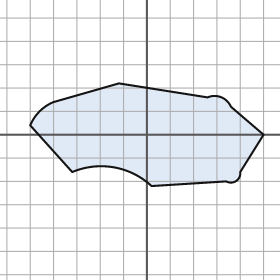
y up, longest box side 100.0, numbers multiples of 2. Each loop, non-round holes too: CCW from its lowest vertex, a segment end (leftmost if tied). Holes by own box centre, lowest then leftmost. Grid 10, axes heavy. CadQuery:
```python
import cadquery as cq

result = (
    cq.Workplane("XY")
    .moveTo(2.0, -22.0)
    .lineTo(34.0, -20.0)
    .threePointArc((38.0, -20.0), (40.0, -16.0))
    .lineTo(50.0, 0.0)
    .lineTo(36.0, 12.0)
    .threePointArc((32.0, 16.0), (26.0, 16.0))
    .lineTo(-12.0, 22.0)
    .lineTo(-40.0, 14.0)
    .threePointArc((-46.0, 10.0), (-50.0, 4.0))
    .lineTo(-32.0, -16.0)
    .threePointArc((-14.0, -14.0), (2.0, -22.0))
    .close()
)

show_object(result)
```